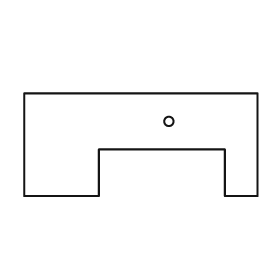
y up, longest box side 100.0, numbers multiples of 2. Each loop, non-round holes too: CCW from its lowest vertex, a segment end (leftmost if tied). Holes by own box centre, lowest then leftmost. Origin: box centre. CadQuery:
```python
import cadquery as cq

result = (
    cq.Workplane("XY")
    .moveTo(-50.0, -22.0)
    .lineTo(-18.0, -22.0)
    .lineTo(-18.0, -2.0)
    .lineTo(36.0, -2.0)
    .lineTo(36.0, -22.0)
    .lineTo(50.0, -22.0)
    .lineTo(50.0, 22.0)
    .lineTo(-50.0, 22.0)
    .close()
    .moveTo(12.0, 10.0)
    .circle(2.0)
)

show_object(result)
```